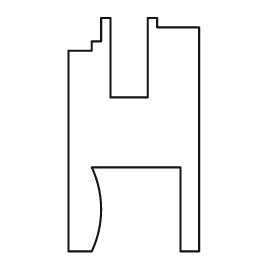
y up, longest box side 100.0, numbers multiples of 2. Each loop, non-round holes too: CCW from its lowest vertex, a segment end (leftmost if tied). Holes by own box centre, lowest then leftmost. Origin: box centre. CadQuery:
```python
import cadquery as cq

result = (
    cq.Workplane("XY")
    .moveTo(-28.0, -50.0)
    .lineTo(-18.0, -50.0)
    .threePointArc((-14.0, -32.0), (-18.0, -14.0))
    .lineTo(20.0, -14.0)
    .lineTo(20.0, -50.0)
    .lineTo(28.0, -50.0)
    .lineTo(28.0, 46.0)
    .lineTo(10.0, 46.0)
    .lineTo(10.0, 50.0)
    .lineTo(6.0, 50.0)
    .lineTo(6.0, 16.0)
    .lineTo(-10.0, 16.0)
    .lineTo(-10.0, 50.0)
    .lineTo(-14.0, 50.0)
    .lineTo(-14.0, 40.0)
    .lineTo(-18.0, 40.0)
    .lineTo(-18.0, 36.0)
    .lineTo(-28.0, 36.0)
    .close()
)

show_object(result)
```